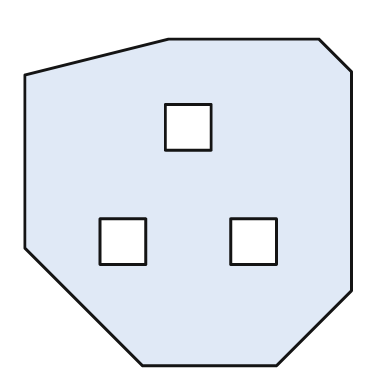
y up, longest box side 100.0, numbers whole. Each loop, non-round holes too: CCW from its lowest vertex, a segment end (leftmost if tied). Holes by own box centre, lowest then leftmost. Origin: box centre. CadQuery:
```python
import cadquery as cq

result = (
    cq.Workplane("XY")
    .moveTo(-14.0, -50.0)
    .lineTo(27.0, -50.0)
    .lineTo(50.0, -27.0)
    .lineTo(50.0, 40.0)
    .lineTo(40.0, 50.0)
    .lineTo(-6.0, 50.0)
    .lineTo(-50.0, 39.0)
    .lineTo(-50.0, -14.0)
    .close()
    .moveTo(-27.0, -19.0)
    .lineTo(-13.0, -19.0)
    .lineTo(-13.0, -5.0)
    .lineTo(-27.0, -5.0)
    .close()
    .moveTo(13.0, -19.0)
    .lineTo(27.0, -19.0)
    .lineTo(27.0, -5.0)
    .lineTo(13.0, -5.0)
    .close()
    .moveTo(-7.0, 16.0)
    .lineTo(7.0, 16.0)
    .lineTo(7.0, 30.0)
    .lineTo(-7.0, 30.0)
    .close()
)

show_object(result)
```